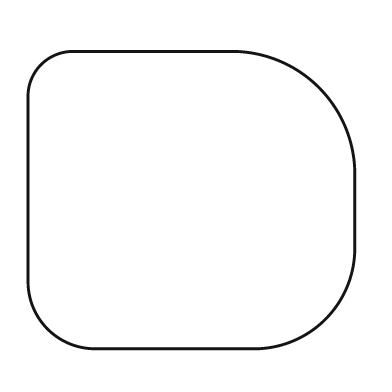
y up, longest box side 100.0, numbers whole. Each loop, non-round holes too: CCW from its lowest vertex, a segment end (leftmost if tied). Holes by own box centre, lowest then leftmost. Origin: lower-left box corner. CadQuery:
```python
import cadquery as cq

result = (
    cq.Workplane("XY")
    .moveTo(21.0, 0.0)
    .lineTo(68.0, 0.0)
    .threePointArc((91.0, 9.0), (100.0, 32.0))
    .lineTo(100.0, 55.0)
    .threePointArc((89.0, 80.0), (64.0, 91.0))
    .lineTo(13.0, 91.0)
    .threePointArc((4.0, 87.0), (0.0, 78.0))
    .lineTo(0.0, 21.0)
    .threePointArc((6.0, 6.0), (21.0, 0.0))
    .close()
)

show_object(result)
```